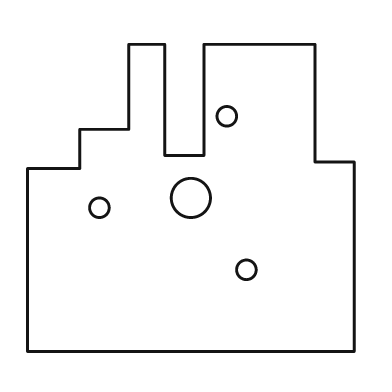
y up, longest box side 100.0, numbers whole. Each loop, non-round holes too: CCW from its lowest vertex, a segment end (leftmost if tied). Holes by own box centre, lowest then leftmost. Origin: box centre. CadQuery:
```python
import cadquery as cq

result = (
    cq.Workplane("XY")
    .moveTo(-50.0, -47.0)
    .lineTo(50.0, -47.0)
    .lineTo(50.0, 11.0)
    .lineTo(38.0, 11.0)
    .lineTo(38.0, 47.0)
    .lineTo(4.0, 47.0)
    .lineTo(4.0, 13.0)
    .lineTo(-8.0, 13.0)
    .lineTo(-8.0, 47.0)
    .lineTo(-19.0, 47.0)
    .lineTo(-19.0, 21.0)
    .lineTo(-34.0, 21.0)
    .lineTo(-34.0, 9.0)
    .lineTo(-50.0, 9.0)
    .close()
    .moveTo(17.0, -22.0)
    .circle(3.0)
    .moveTo(-28.0, -3.0)
    .circle(3.0)
    .moveTo(0.0, 0.0)
    .circle(6.0)
    .moveTo(11.0, 25.0)
    .circle(3.0)
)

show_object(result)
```